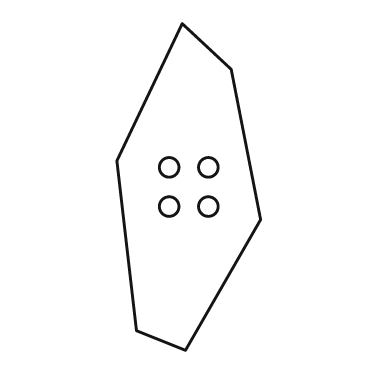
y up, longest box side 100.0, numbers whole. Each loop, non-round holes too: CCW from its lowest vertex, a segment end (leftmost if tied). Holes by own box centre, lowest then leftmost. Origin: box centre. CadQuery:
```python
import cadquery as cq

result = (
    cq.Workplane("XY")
    .moveTo(-1.0, -50.0)
    .lineTo(22.0, -10.0)
    .lineTo(13.0, 36.0)
    .lineTo(-2.0, 50.0)
    .lineTo(-22.0, 8.0)
    .lineTo(-16.0, -44.0)
    .close()
    .moveTo(-6.0, -6.0)
    .circle(3.0)
    .moveTo(6.0, -6.0)
    .circle(3.0)
    .moveTo(-6.0, 6.0)
    .circle(3.0)
    .moveTo(6.0, 6.0)
    .circle(3.0)
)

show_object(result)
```